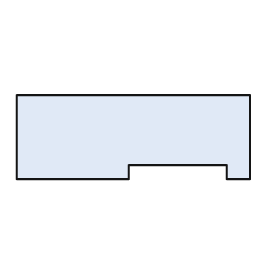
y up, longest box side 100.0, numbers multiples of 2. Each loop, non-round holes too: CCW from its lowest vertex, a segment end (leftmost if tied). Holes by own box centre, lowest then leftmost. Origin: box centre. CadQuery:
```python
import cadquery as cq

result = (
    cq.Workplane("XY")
    .moveTo(-50.0, -18.0)
    .lineTo(-2.0, -18.0)
    .lineTo(-2.0, -12.0)
    .lineTo(40.0, -12.0)
    .lineTo(40.0, -18.0)
    .lineTo(50.0, -18.0)
    .lineTo(50.0, 18.0)
    .lineTo(-50.0, 18.0)
    .close()
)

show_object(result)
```